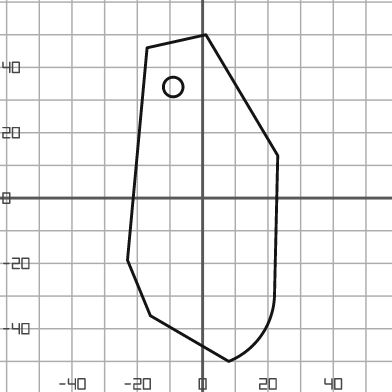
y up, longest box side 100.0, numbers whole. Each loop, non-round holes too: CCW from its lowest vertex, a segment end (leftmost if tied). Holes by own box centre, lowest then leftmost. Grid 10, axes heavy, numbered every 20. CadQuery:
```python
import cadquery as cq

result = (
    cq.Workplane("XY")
    .moveTo(8.0, -50.0)
    .threePointArc((18.0, -42.0), (22.0, -30.0))
    .lineTo(23.0, 13.0)
    .lineTo(1.0, 50.0)
    .lineTo(-17.0, 46.0)
    .lineTo(-23.0, -19.0)
    .lineTo(-16.0, -36.0)
    .close()
    .moveTo(-9.0, 34.0)
    .circle(3.0)
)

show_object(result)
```